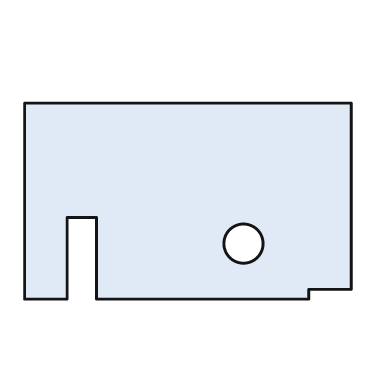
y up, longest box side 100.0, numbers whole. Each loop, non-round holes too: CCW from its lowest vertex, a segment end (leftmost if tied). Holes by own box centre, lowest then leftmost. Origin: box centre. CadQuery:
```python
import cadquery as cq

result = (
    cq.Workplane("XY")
    .moveTo(-50.0, -30.0)
    .lineTo(-37.0, -30.0)
    .lineTo(-37.0, -5.0)
    .lineTo(-28.0, -5.0)
    .lineTo(-28.0, -30.0)
    .lineTo(37.0, -30.0)
    .lineTo(37.0, -27.0)
    .lineTo(50.0, -27.0)
    .lineTo(50.0, 30.0)
    .lineTo(-50.0, 30.0)
    .close()
    .moveTo(17.0, -13.0)
    .circle(6.0)
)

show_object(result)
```